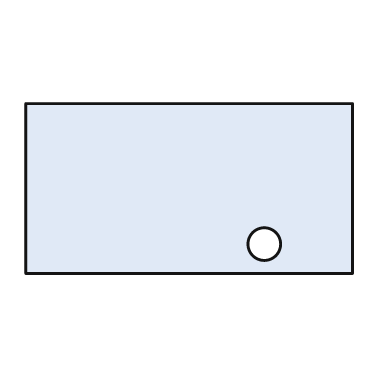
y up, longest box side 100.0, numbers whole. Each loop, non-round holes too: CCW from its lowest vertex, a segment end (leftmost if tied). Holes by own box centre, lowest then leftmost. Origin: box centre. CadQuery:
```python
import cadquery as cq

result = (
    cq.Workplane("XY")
    .moveTo(-50.0, -26.0)
    .lineTo(50.0, -26.0)
    .lineTo(50.0, 26.0)
    .lineTo(-50.0, 26.0)
    .close()
    .moveTo(23.0, -17.0)
    .circle(5.0)
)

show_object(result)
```